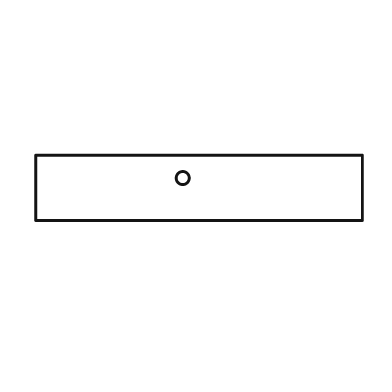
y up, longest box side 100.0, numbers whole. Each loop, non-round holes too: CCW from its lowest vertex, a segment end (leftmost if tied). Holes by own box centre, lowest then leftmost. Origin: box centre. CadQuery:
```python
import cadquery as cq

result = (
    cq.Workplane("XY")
    .moveTo(-50.0, -10.0)
    .lineTo(50.0, -10.0)
    .lineTo(50.0, 10.0)
    .lineTo(-50.0, 10.0)
    .close()
    .moveTo(-5.0, 3.0)
    .circle(2.0)
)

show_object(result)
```